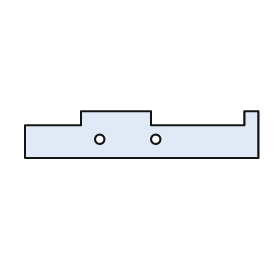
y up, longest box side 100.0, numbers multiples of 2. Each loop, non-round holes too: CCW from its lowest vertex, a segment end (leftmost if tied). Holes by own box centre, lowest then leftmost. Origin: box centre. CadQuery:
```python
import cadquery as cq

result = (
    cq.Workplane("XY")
    .moveTo(-50.0, -10.0)
    .lineTo(50.0, -10.0)
    .lineTo(50.0, 10.0)
    .lineTo(44.0, 10.0)
    .lineTo(44.0, 4.0)
    .lineTo(4.0, 4.0)
    .lineTo(4.0, 10.0)
    .lineTo(-26.0, 10.0)
    .lineTo(-26.0, 4.0)
    .lineTo(-50.0, 4.0)
    .close()
    .moveTo(-18.0, -2.0)
    .circle(2.0)
    .moveTo(6.0, -2.0)
    .circle(2.0)
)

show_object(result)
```